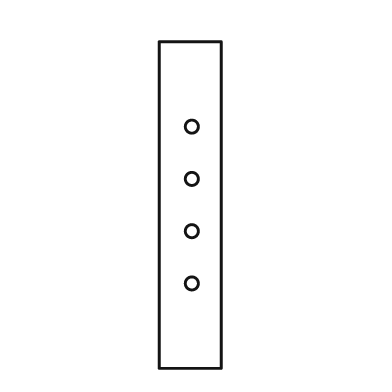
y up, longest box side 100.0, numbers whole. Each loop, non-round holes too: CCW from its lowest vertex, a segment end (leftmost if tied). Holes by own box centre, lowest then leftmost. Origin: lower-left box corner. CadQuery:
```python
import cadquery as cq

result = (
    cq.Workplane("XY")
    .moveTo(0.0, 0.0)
    .lineTo(19.0, 0.0)
    .lineTo(19.0, 100.0)
    .lineTo(0.0, 100.0)
    .close()
    .moveTo(10.0, 26.0)
    .circle(2.0)
    .moveTo(10.0, 42.0)
    .circle(2.0)
    .moveTo(10.0, 58.0)
    .circle(2.0)
    .moveTo(10.0, 74.0)
    .circle(2.0)
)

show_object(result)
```